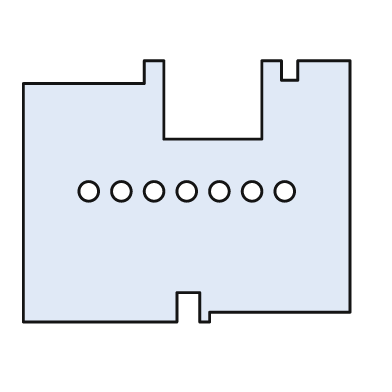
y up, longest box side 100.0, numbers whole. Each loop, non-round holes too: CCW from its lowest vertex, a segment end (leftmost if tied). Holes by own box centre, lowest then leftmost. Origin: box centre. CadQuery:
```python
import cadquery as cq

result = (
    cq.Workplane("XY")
    .moveTo(-50.0, -40.0)
    .lineTo(-3.0, -40.0)
    .lineTo(-3.0, -31.0)
    .lineTo(4.0, -31.0)
    .lineTo(4.0, -40.0)
    .lineTo(7.0, -40.0)
    .lineTo(7.0, -37.0)
    .lineTo(50.0, -37.0)
    .lineTo(50.0, 40.0)
    .lineTo(34.0, 40.0)
    .lineTo(34.0, 34.0)
    .lineTo(29.0, 34.0)
    .lineTo(29.0, 40.0)
    .lineTo(23.0, 40.0)
    .lineTo(23.0, 16.0)
    .lineTo(-7.0, 16.0)
    .lineTo(-7.0, 40.0)
    .lineTo(-13.0, 40.0)
    .lineTo(-13.0, 33.0)
    .lineTo(-50.0, 33.0)
    .close()
    .moveTo(-30.0, 0.0)
    .circle(3.0)
    .moveTo(-20.0, 0.0)
    .circle(3.0)
    .moveTo(-10.0, 0.0)
    .circle(3.0)
    .moveTo(0.0, 0.0)
    .circle(3.0)
    .moveTo(10.0, 0.0)
    .circle(3.0)
    .moveTo(20.0, 0.0)
    .circle(3.0)
    .moveTo(30.0, 0.0)
    .circle(3.0)
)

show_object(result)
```